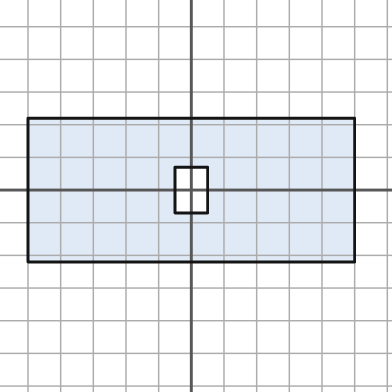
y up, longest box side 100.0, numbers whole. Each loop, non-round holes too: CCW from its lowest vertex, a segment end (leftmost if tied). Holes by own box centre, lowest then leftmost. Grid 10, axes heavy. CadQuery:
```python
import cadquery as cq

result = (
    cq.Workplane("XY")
    .moveTo(-50.0, -22.0)
    .lineTo(50.0, -22.0)
    .lineTo(50.0, 22.0)
    .lineTo(-50.0, 22.0)
    .close()
    .moveTo(-5.0, -7.0)
    .lineTo(5.0, -7.0)
    .lineTo(5.0, 7.0)
    .lineTo(-5.0, 7.0)
    .close()
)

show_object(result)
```